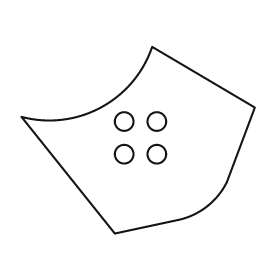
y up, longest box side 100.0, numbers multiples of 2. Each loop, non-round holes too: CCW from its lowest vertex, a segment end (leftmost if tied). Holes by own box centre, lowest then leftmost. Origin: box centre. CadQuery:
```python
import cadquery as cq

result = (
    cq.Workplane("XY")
    .moveTo(-10.0, -40.0)
    .lineTo(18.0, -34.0)
    .threePointArc((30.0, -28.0), (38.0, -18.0))
    .lineTo(50.0, 14.0)
    .lineTo(6.0, 40.0)
    .threePointArc((-16.0, 14.0), (-50.0, 10.0))
    .close()
    .moveTo(-6.0, -6.0)
    .circle(4.0)
    .moveTo(8.0, -6.0)
    .circle(4.0)
    .moveTo(-6.0, 8.0)
    .circle(4.0)
    .moveTo(8.0, 8.0)
    .circle(4.0)
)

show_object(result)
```